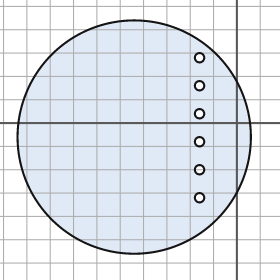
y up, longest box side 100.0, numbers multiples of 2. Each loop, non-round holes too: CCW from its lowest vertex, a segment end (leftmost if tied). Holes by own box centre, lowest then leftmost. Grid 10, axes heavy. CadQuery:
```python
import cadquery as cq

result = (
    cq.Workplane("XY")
    .moveTo(-44.0, -6.0)
    .circle(50.0)
    .moveTo(-16.0, -32.0)
    .circle(2.0)
    .moveTo(-16.0, -20.0)
    .circle(2.0)
    .moveTo(-16.0, -8.0)
    .circle(2.0)
    .moveTo(-16.0, 4.0)
    .circle(2.0)
    .moveTo(-16.0, 16.0)
    .circle(2.0)
    .moveTo(-16.0, 28.0)
    .circle(2.0)
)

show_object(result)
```